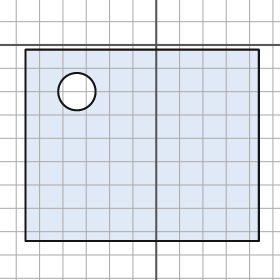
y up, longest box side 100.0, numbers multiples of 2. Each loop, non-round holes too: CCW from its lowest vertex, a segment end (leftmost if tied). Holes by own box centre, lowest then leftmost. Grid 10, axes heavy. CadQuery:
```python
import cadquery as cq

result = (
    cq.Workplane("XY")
    .moveTo(-56.0, -84.0)
    .lineTo(44.0, -84.0)
    .lineTo(44.0, -2.0)
    .lineTo(-56.0, -2.0)
    .close()
    .moveTo(-34.0, -20.0)
    .circle(8.0)
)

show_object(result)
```